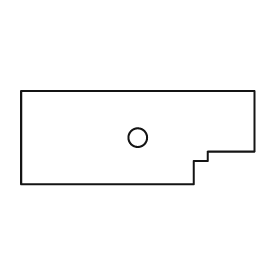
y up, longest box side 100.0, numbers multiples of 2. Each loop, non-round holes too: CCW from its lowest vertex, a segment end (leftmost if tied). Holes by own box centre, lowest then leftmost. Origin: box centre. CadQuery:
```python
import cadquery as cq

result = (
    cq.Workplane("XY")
    .moveTo(-50.0, -20.0)
    .lineTo(24.0, -20.0)
    .lineTo(24.0, -10.0)
    .lineTo(30.0, -10.0)
    .lineTo(30.0, -6.0)
    .lineTo(50.0, -6.0)
    .lineTo(50.0, 20.0)
    .lineTo(-50.0, 20.0)
    .close()
    .moveTo(0.0, 0.0)
    .circle(4.0)
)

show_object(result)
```